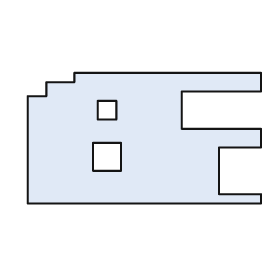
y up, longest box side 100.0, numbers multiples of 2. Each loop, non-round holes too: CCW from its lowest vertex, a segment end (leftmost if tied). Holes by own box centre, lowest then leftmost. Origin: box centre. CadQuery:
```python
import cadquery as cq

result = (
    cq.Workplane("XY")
    .moveTo(-50.0, -28.0)
    .lineTo(50.0, -28.0)
    .lineTo(50.0, -24.0)
    .lineTo(32.0, -24.0)
    .lineTo(32.0, -4.0)
    .lineTo(50.0, -4.0)
    .lineTo(50.0, 4.0)
    .lineTo(16.0, 4.0)
    .lineTo(16.0, 20.0)
    .lineTo(50.0, 20.0)
    .lineTo(50.0, 28.0)
    .lineTo(-30.0, 28.0)
    .lineTo(-30.0, 24.0)
    .lineTo(-42.0, 24.0)
    .lineTo(-42.0, 18.0)
    .lineTo(-50.0, 18.0)
    .close()
    .moveTo(-22.0, -14.0)
    .lineTo(-10.0, -14.0)
    .lineTo(-10.0, -2.0)
    .lineTo(-22.0, -2.0)
    .close()
    .moveTo(-20.0, 8.0)
    .lineTo(-12.0, 8.0)
    .lineTo(-12.0, 16.0)
    .lineTo(-20.0, 16.0)
    .close()
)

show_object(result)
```